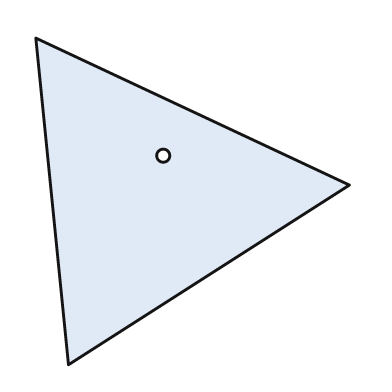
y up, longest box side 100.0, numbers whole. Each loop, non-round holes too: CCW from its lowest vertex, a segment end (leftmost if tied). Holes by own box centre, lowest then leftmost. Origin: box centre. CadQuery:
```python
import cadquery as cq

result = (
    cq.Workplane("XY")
    .moveTo(-38.0, -50.0)
    .lineTo(48.0, 5.0)
    .lineTo(-48.0, 50.0)
    .close()
    .moveTo(-9.0, 14.0)
    .circle(2.0)
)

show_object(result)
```